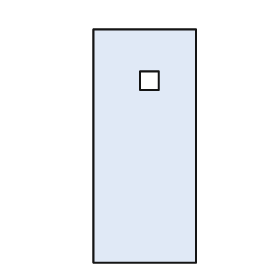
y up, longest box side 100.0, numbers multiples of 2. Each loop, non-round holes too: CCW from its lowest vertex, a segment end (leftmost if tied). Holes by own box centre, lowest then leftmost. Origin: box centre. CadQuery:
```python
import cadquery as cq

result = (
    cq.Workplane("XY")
    .moveTo(-22.0, -50.0)
    .lineTo(22.0, -50.0)
    .lineTo(22.0, 50.0)
    .lineTo(-22.0, 50.0)
    .close()
    .moveTo(-2.0, 24.0)
    .lineTo(6.0, 24.0)
    .lineTo(6.0, 32.0)
    .lineTo(-2.0, 32.0)
    .close()
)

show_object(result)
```